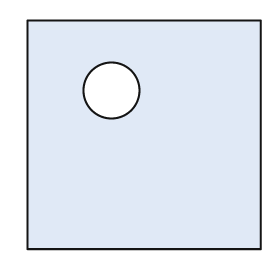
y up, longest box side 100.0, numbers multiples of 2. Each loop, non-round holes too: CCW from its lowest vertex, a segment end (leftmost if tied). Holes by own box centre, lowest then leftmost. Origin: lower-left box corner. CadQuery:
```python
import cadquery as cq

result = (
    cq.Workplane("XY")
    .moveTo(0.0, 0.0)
    .lineTo(100.0, 0.0)
    .lineTo(100.0, 98.0)
    .lineTo(0.0, 98.0)
    .close()
    .moveTo(36.0, 68.0)
    .circle(12.0)
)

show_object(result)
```